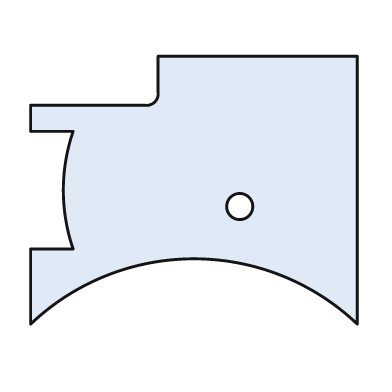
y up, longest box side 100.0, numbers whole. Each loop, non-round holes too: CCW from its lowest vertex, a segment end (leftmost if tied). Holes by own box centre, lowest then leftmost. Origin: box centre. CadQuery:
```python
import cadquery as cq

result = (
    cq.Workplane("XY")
    .moveTo(-50.0, -41.0)
    .threePointArc((0.0, -21.0), (50.0, -41.0))
    .lineTo(50.0, 41.0)
    .lineTo(-11.0, 41.0)
    .lineTo(-11.0, 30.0)
    .threePointArc((-12.0, 27.0), (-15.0, 26.0))
    .lineTo(-50.0, 26.0)
    .lineTo(-50.0, 18.0)
    .lineTo(-37.0, 18.0)
    .threePointArc((-40.0, 0.0), (-37.0, -18.0))
    .lineTo(-50.0, -18.0)
    .close()
    .moveTo(14.0, -5.0)
    .circle(4.0)
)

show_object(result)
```